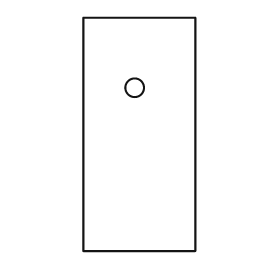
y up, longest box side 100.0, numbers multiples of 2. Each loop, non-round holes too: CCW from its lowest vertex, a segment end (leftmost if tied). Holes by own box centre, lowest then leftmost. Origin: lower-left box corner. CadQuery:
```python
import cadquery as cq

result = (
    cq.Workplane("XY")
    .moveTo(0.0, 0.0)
    .lineTo(48.0, 0.0)
    .lineTo(48.0, 100.0)
    .lineTo(0.0, 100.0)
    .close()
    .moveTo(22.0, 70.0)
    .circle(4.0)
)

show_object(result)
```